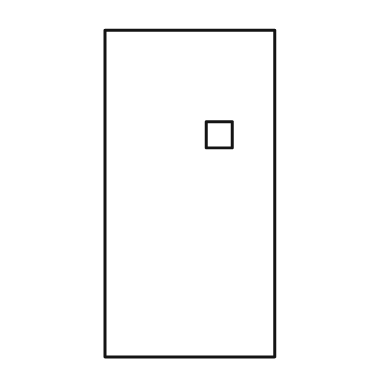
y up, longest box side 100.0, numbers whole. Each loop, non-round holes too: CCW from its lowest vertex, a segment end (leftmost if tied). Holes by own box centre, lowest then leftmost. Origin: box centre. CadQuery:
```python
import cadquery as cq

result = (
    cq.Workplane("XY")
    .moveTo(-26.0, -50.0)
    .lineTo(26.0, -50.0)
    .lineTo(26.0, 50.0)
    .lineTo(-26.0, 50.0)
    .close()
    .moveTo(5.0, 14.0)
    .lineTo(13.0, 14.0)
    .lineTo(13.0, 22.0)
    .lineTo(5.0, 22.0)
    .close()
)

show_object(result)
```